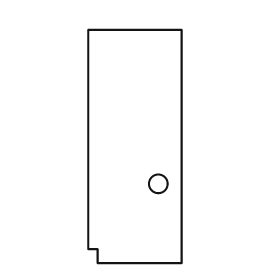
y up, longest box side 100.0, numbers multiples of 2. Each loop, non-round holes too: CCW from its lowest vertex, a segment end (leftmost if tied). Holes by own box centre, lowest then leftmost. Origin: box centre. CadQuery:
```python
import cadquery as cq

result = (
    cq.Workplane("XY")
    .moveTo(-16.0, -50.0)
    .lineTo(20.0, -50.0)
    .lineTo(20.0, 50.0)
    .lineTo(-20.0, 50.0)
    .lineTo(-20.0, -44.0)
    .lineTo(-16.0, -44.0)
    .close()
    .moveTo(10.0, -16.0)
    .circle(4.0)
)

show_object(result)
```